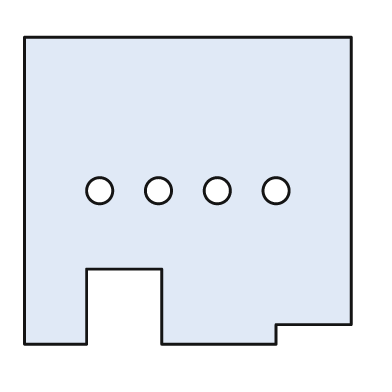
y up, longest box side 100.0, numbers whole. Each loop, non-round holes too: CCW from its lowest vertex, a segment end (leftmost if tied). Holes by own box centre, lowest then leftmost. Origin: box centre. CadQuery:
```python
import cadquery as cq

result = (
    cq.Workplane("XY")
    .moveTo(-50.0, -47.0)
    .lineTo(-31.0, -47.0)
    .lineTo(-31.0, -24.0)
    .lineTo(-8.0, -24.0)
    .lineTo(-8.0, -47.0)
    .lineTo(27.0, -47.0)
    .lineTo(27.0, -41.0)
    .lineTo(50.0, -41.0)
    .lineTo(50.0, 47.0)
    .lineTo(-50.0, 47.0)
    .close()
    .moveTo(-27.0, 0.0)
    .circle(4.0)
    .moveTo(-9.0, 0.0)
    .circle(4.0)
    .moveTo(9.0, 0.0)
    .circle(4.0)
    .moveTo(27.0, 0.0)
    .circle(4.0)
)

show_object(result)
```